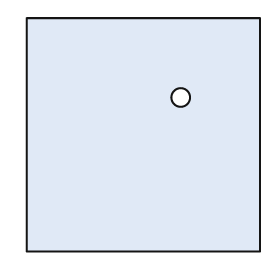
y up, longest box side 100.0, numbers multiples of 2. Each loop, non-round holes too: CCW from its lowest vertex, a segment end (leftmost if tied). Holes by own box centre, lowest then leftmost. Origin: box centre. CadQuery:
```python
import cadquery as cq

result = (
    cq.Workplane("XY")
    .moveTo(-50.0, -50.0)
    .lineTo(50.0, -50.0)
    .lineTo(50.0, 50.0)
    .lineTo(-50.0, 50.0)
    .close()
    .moveTo(16.0, 16.0)
    .circle(4.0)
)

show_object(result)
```